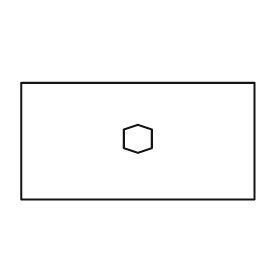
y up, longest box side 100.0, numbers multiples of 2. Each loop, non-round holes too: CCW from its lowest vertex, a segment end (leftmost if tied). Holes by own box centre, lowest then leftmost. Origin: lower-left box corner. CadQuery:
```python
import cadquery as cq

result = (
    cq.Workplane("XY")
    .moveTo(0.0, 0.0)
    .lineTo(100.0, 0.0)
    .lineTo(100.0, 50.0)
    .lineTo(0.0, 50.0)
    .close()
    .moveTo(50.0, 20.0)
    .lineTo(56.0, 22.0)
    .lineTo(56.0, 30.0)
    .lineTo(50.0, 32.0)
    .lineTo(44.0, 30.0)
    .lineTo(44.0, 22.0)
    .close()
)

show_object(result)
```